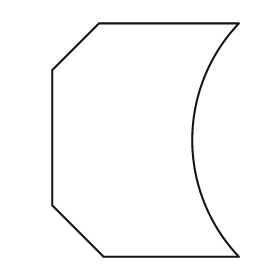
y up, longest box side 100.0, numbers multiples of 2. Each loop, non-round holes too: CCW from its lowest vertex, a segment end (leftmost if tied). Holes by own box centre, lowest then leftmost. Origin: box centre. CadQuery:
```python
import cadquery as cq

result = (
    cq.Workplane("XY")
    .moveTo(-18.0, -50.0)
    .lineTo(40.0, -50.0)
    .threePointArc((20.0, 0.0), (40.0, 50.0))
    .lineTo(-20.0, 50.0)
    .lineTo(-40.0, 30.0)
    .lineTo(-40.0, -28.0)
    .close()
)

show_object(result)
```